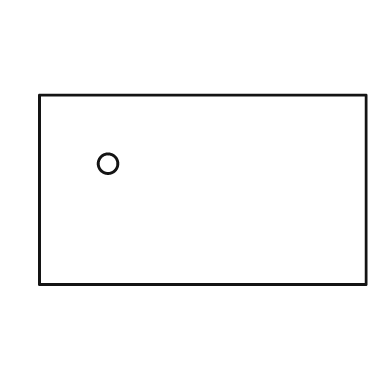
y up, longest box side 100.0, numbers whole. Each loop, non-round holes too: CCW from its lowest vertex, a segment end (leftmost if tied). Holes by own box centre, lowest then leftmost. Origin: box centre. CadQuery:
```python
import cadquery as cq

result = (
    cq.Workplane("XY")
    .moveTo(-50.0, -29.0)
    .lineTo(50.0, -29.0)
    .lineTo(50.0, 29.0)
    .lineTo(-50.0, 29.0)
    .close()
    .moveTo(-29.0, 8.0)
    .circle(3.0)
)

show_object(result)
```